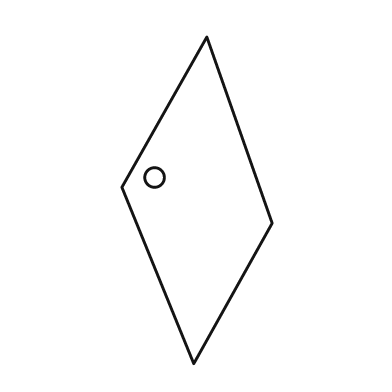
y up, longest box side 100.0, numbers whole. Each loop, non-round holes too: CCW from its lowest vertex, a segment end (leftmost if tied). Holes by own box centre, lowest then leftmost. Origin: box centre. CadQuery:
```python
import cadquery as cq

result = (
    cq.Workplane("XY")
    .moveTo(-1.0, -50.0)
    .lineTo(23.0, -7.0)
    .lineTo(3.0, 50.0)
    .lineTo(-23.0, 4.0)
    .close()
    .moveTo(-13.0, 7.0)
    .circle(3.0)
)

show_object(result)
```